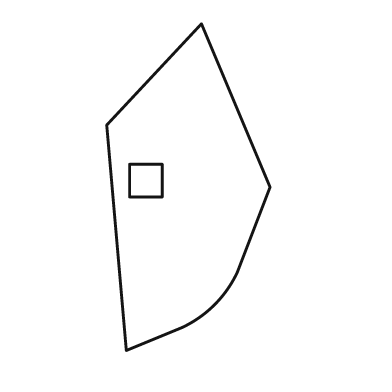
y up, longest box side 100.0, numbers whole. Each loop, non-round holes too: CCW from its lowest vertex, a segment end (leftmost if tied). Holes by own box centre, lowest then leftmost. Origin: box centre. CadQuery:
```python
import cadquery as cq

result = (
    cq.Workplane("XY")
    .moveTo(-19.0, -50.0)
    .lineTo(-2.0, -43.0)
    .threePointArc((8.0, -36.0), (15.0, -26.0))
    .lineTo(25.0, 0.0)
    .lineTo(4.0, 50.0)
    .lineTo(-25.0, 19.0)
    .close()
    .moveTo(-18.0, -3.0)
    .lineTo(-8.0, -3.0)
    .lineTo(-8.0, 7.0)
    .lineTo(-18.0, 7.0)
    .close()
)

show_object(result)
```